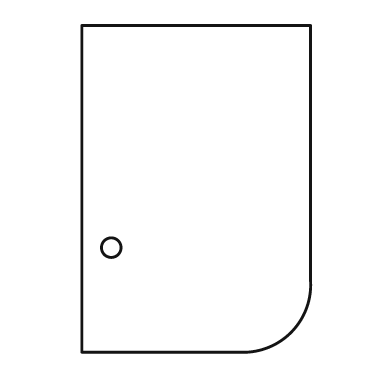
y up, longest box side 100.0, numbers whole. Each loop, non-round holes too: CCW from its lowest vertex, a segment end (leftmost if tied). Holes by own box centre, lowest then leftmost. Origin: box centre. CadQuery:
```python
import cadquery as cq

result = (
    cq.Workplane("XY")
    .moveTo(-35.0, -50.0)
    .lineTo(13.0, -50.0)
    .threePointArc((29.0, -44.0), (35.0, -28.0))
    .lineTo(35.0, 50.0)
    .lineTo(-35.0, 50.0)
    .close()
    .moveTo(-26.0, -18.0)
    .circle(3.0)
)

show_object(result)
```